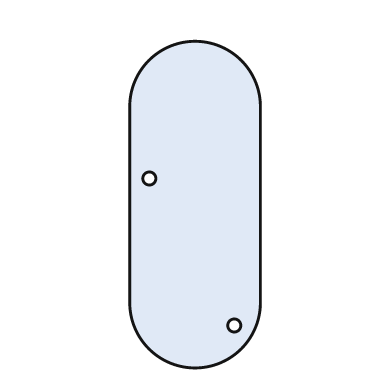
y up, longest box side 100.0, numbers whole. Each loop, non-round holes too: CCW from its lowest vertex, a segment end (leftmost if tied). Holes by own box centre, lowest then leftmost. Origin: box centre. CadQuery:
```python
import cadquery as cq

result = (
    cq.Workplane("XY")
    .moveTo(-20.0, -30.0)
    .threePointArc((0.0, -50.0), (20.0, -30.0))
    .lineTo(20.0, 30.0)
    .threePointArc((0.0, 50.0), (-20.0, 30.0))
    .close()
    .moveTo(12.0, -37.0)
    .circle(2.0)
    .moveTo(-14.0, 8.0)
    .circle(2.0)
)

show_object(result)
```